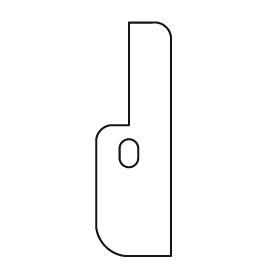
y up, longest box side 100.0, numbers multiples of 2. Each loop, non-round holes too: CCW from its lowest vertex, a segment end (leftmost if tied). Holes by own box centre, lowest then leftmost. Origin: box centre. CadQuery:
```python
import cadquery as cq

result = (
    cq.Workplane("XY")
    .moveTo(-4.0, -50.0)
    .lineTo(16.0, -50.0)
    .lineTo(16.0, 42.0)
    .threePointArc((14.0, 48.0), (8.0, 50.0))
    .lineTo(-2.0, 50.0)
    .lineTo(-2.0, 6.0)
    .lineTo(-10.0, 6.0)
    .threePointArc((-14.0, 4.0), (-16.0, 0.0))
    .lineTo(-16.0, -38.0)
    .threePointArc((-12.0, -46.0), (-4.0, -50.0))
    .close()
    .moveTo(-6.0, -8.0)
    .threePointArc((-2.0, -12.0), (2.0, -8.0))
    .lineTo(2.0, -4.0)
    .threePointArc((-2.0, 0.0), (-6.0, -4.0))
    .close()
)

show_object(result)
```